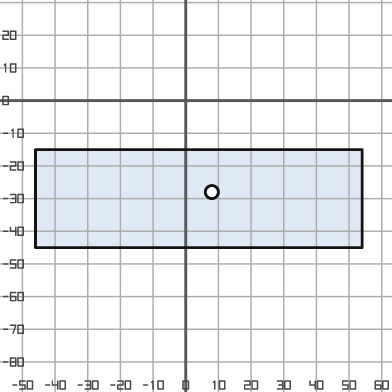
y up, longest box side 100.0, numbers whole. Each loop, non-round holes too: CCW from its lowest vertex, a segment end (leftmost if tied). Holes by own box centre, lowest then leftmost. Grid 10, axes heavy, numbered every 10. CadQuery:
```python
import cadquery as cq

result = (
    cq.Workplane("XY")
    .moveTo(-46.0, -45.0)
    .lineTo(54.0, -45.0)
    .lineTo(54.0, -15.0)
    .lineTo(-46.0, -15.0)
    .close()
    .moveTo(8.0, -28.0)
    .circle(2.0)
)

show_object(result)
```